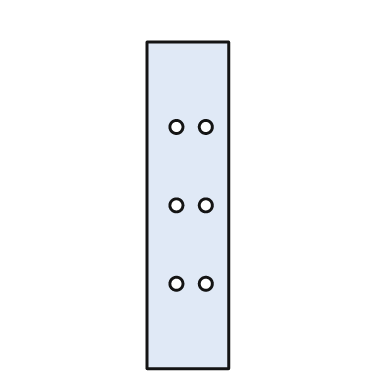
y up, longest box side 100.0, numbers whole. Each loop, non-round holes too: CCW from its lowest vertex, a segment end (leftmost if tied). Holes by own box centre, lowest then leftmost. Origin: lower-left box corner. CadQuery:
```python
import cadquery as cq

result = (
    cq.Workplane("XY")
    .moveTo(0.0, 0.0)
    .lineTo(25.0, 0.0)
    .lineTo(25.0, 100.0)
    .lineTo(0.0, 100.0)
    .close()
    .moveTo(9.0, 26.0)
    .circle(2.0)
    .moveTo(18.0, 26.0)
    .circle(2.0)
    .moveTo(9.0, 50.0)
    .circle(2.0)
    .moveTo(18.0, 50.0)
    .circle(2.0)
    .moveTo(9.0, 74.0)
    .circle(2.0)
    .moveTo(18.0, 74.0)
    .circle(2.0)
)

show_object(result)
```